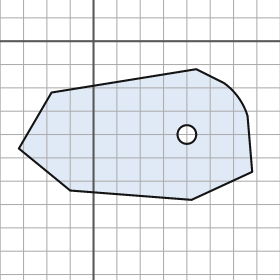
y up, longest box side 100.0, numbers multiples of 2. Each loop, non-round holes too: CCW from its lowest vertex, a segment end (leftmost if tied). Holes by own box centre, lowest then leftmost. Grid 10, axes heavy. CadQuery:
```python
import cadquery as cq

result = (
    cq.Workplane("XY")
    .moveTo(42.0, -68.0)
    .lineTo(68.0, -56.0)
    .lineTo(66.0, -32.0)
    .threePointArc((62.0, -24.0), (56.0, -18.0))
    .lineTo(44.0, -12.0)
    .lineTo(-18.0, -22.0)
    .lineTo(-32.0, -46.0)
    .lineTo(-10.0, -64.0)
    .close()
    .moveTo(40.0, -40.0)
    .circle(4.0)
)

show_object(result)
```